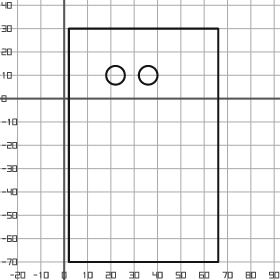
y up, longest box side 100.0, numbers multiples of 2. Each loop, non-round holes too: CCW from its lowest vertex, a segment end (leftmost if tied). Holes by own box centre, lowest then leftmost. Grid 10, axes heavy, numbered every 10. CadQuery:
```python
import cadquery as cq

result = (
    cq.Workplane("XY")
    .moveTo(2.0, -70.0)
    .lineTo(66.0, -70.0)
    .lineTo(66.0, 30.0)
    .lineTo(2.0, 30.0)
    .close()
    .moveTo(22.0, 10.0)
    .circle(4.0)
    .moveTo(36.0, 10.0)
    .circle(4.0)
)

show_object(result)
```